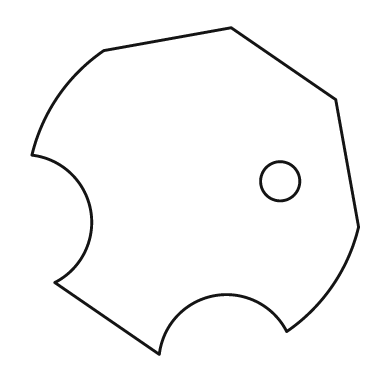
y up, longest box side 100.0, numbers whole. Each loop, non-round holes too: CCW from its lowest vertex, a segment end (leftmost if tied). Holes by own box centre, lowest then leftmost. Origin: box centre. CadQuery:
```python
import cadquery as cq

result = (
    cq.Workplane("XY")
    .moveTo(-11.0, -50.0)
    .threePointArc((6.0, -32.0), (28.0, -43.0))
    .threePointArc((42.0, -29.0), (50.0, -11.0))
    .lineTo(43.0, 28.0)
    .lineTo(11.0, 50.0)
    .lineTo(-28.0, 43.0)
    .threePointArc((-42.0, 29.0), (-50.0, 11.0))
    .threePointArc((-32.0, -6.0), (-43.0, -28.0))
    .close()
    .moveTo(26.0, 3.0)
    .circle(6.0)
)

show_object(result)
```